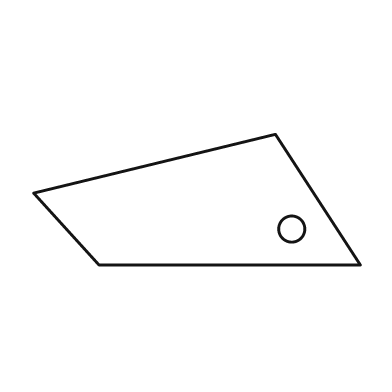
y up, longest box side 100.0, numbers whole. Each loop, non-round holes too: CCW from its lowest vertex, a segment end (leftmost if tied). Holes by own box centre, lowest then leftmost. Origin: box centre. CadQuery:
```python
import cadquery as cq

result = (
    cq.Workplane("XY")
    .moveTo(-30.0, -20.0)
    .lineTo(50.0, -20.0)
    .lineTo(24.0, 20.0)
    .lineTo(-50.0, 2.0)
    .close()
    .moveTo(29.0, -9.0)
    .circle(4.0)
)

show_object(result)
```